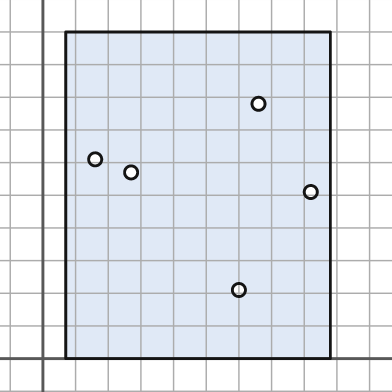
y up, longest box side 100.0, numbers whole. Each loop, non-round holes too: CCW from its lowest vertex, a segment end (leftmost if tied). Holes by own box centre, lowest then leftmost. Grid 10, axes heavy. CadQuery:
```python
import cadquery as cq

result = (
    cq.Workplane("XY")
    .moveTo(7.0, 0.0)
    .lineTo(88.0, 0.0)
    .lineTo(88.0, 100.0)
    .lineTo(7.0, 100.0)
    .close()
    .moveTo(60.0, 21.0)
    .circle(2.0)
    .moveTo(82.0, 51.0)
    .circle(2.0)
    .moveTo(27.0, 57.0)
    .circle(2.0)
    .moveTo(16.0, 61.0)
    .circle(2.0)
    .moveTo(66.0, 78.0)
    .circle(2.0)
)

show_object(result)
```